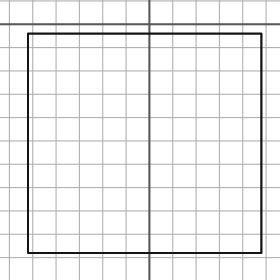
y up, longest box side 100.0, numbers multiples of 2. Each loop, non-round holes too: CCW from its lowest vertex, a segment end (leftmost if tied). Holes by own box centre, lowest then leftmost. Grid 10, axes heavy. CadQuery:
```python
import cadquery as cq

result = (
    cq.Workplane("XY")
    .moveTo(-52.0, -98.0)
    .lineTo(48.0, -98.0)
    .lineTo(48.0, -4.0)
    .lineTo(-52.0, -4.0)
    .close()
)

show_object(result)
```